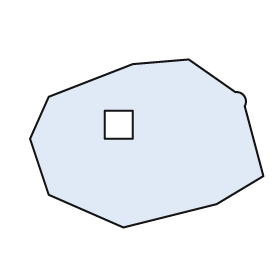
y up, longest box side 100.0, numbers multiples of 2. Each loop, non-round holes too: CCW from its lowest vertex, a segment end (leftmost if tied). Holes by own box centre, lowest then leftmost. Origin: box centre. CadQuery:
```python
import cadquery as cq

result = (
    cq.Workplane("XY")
    .moveTo(-10.0, -36.0)
    .lineTo(30.0, -26.0)
    .lineTo(50.0, -14.0)
    .lineTo(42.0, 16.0)
    .threePointArc((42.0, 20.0), (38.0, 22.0))
    .lineTo(18.0, 36.0)
    .lineTo(-6.0, 34.0)
    .lineTo(-42.0, 20.0)
    .lineTo(-50.0, 2.0)
    .lineTo(-42.0, -22.0)
    .close()
    .moveTo(-18.0, 2.0)
    .lineTo(-6.0, 2.0)
    .lineTo(-6.0, 14.0)
    .lineTo(-18.0, 14.0)
    .close()
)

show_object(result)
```